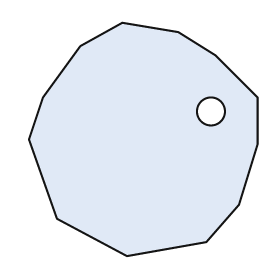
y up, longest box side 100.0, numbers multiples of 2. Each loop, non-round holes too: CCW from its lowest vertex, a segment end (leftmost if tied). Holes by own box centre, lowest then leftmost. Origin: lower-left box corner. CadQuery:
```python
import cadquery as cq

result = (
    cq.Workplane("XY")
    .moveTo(42.0, 0.0)
    .lineTo(76.0, 6.0)
    .lineTo(90.0, 22.0)
    .lineTo(98.0, 48.0)
    .lineTo(98.0, 68.0)
    .lineTo(80.0, 86.0)
    .lineTo(64.0, 96.0)
    .lineTo(40.0, 100.0)
    .lineTo(22.0, 90.0)
    .lineTo(6.0, 68.0)
    .lineTo(0.0, 50.0)
    .lineTo(12.0, 16.0)
    .close()
    .moveTo(78.0, 62.0)
    .circle(6.0)
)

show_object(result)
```